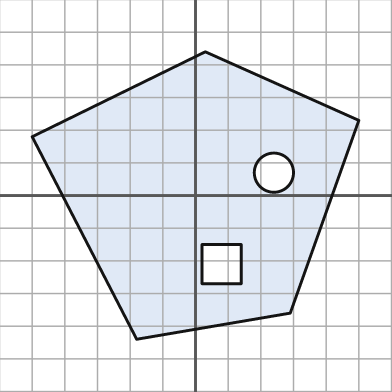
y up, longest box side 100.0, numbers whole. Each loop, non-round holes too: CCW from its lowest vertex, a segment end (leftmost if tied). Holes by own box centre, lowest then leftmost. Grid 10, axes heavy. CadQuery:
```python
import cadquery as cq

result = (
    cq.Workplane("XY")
    .moveTo(-18.0, -44.0)
    .lineTo(29.0, -36.0)
    .lineTo(50.0, 23.0)
    .lineTo(3.0, 44.0)
    .lineTo(-50.0, 18.0)
    .close()
    .moveTo(2.0, -27.0)
    .lineTo(14.0, -27.0)
    .lineTo(14.0, -15.0)
    .lineTo(2.0, -15.0)
    .close()
    .moveTo(24.0, 7.0)
    .circle(6.0)
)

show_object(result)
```